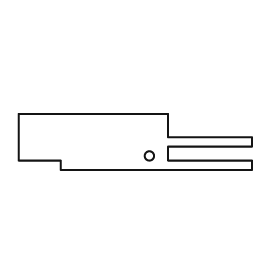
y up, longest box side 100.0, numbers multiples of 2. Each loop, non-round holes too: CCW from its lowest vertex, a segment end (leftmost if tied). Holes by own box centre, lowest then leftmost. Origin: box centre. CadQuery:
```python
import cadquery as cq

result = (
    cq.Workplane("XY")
    .moveTo(-32.0, -12.0)
    .lineTo(50.0, -12.0)
    .lineTo(50.0, -8.0)
    .lineTo(14.0, -8.0)
    .lineTo(14.0, -2.0)
    .lineTo(50.0, -2.0)
    .lineTo(50.0, 2.0)
    .lineTo(14.0, 2.0)
    .lineTo(14.0, 12.0)
    .lineTo(-50.0, 12.0)
    .lineTo(-50.0, -8.0)
    .lineTo(-32.0, -8.0)
    .close()
    .moveTo(6.0, -6.0)
    .circle(2.0)
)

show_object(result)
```